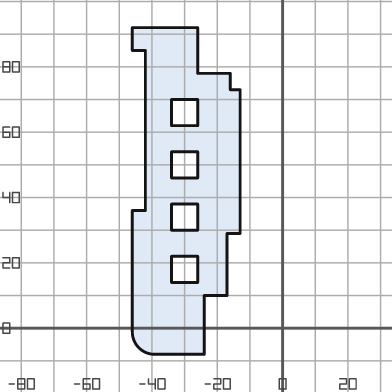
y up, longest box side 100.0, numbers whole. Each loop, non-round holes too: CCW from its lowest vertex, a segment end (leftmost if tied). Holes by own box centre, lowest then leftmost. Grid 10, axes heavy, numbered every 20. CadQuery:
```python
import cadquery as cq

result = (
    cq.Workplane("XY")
    .moveTo(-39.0, -8.0)
    .lineTo(-24.0, -8.0)
    .lineTo(-24.0, 10.0)
    .lineTo(-17.0, 10.0)
    .lineTo(-17.0, 29.0)
    .lineTo(-13.0, 29.0)
    .lineTo(-13.0, 73.0)
    .lineTo(-16.0, 73.0)
    .lineTo(-16.0, 78.0)
    .lineTo(-26.0, 78.0)
    .lineTo(-26.0, 92.0)
    .lineTo(-46.0, 92.0)
    .lineTo(-46.0, 85.0)
    .lineTo(-42.0, 85.0)
    .lineTo(-42.0, 36.0)
    .lineTo(-46.0, 36.0)
    .lineTo(-46.0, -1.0)
    .threePointArc((-44.0, -6.0), (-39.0, -8.0))
    .close()
    .moveTo(-34.0, 14.0)
    .lineTo(-26.0, 14.0)
    .lineTo(-26.0, 22.0)
    .lineTo(-34.0, 22.0)
    .close()
    .moveTo(-34.0, 30.0)
    .lineTo(-26.0, 30.0)
    .lineTo(-26.0, 38.0)
    .lineTo(-34.0, 38.0)
    .close()
    .moveTo(-34.0, 46.0)
    .lineTo(-26.0, 46.0)
    .lineTo(-26.0, 54.0)
    .lineTo(-34.0, 54.0)
    .close()
    .moveTo(-34.0, 62.0)
    .lineTo(-26.0, 62.0)
    .lineTo(-26.0, 70.0)
    .lineTo(-34.0, 70.0)
    .close()
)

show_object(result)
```